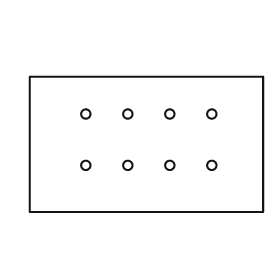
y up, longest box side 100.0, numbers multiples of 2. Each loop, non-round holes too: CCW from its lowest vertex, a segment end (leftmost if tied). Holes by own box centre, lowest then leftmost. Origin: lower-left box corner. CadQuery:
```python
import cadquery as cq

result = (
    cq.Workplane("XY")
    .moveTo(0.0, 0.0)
    .lineTo(100.0, 0.0)
    .lineTo(100.0, 58.0)
    .lineTo(0.0, 58.0)
    .close()
    .moveTo(24.0, 20.0)
    .circle(2.0)
    .moveTo(42.0, 20.0)
    .circle(2.0)
    .moveTo(60.0, 20.0)
    .circle(2.0)
    .moveTo(78.0, 20.0)
    .circle(2.0)
    .moveTo(24.0, 42.0)
    .circle(2.0)
    .moveTo(42.0, 42.0)
    .circle(2.0)
    .moveTo(60.0, 42.0)
    .circle(2.0)
    .moveTo(78.0, 42.0)
    .circle(2.0)
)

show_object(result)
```